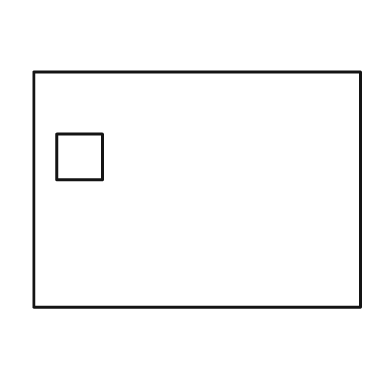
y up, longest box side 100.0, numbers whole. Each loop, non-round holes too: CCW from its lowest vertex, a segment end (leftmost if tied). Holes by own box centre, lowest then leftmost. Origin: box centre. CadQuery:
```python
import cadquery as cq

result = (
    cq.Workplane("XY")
    .moveTo(-50.0, -36.0)
    .lineTo(50.0, -36.0)
    .lineTo(50.0, 36.0)
    .lineTo(-50.0, 36.0)
    .close()
    .moveTo(-43.0, 3.0)
    .lineTo(-29.0, 3.0)
    .lineTo(-29.0, 17.0)
    .lineTo(-43.0, 17.0)
    .close()
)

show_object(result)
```